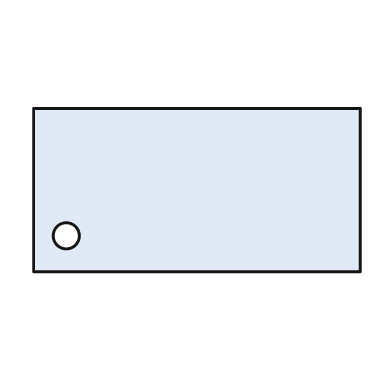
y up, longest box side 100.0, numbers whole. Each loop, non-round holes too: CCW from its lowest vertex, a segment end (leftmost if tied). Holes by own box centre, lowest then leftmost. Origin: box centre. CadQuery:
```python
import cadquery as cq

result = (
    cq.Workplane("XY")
    .moveTo(-50.0, -25.0)
    .lineTo(50.0, -25.0)
    .lineTo(50.0, 25.0)
    .lineTo(-50.0, 25.0)
    .close()
    .moveTo(-40.0, -14.0)
    .circle(4.0)
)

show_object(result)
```